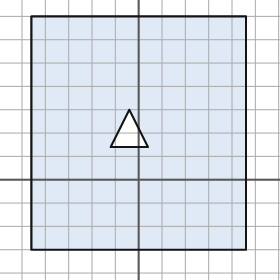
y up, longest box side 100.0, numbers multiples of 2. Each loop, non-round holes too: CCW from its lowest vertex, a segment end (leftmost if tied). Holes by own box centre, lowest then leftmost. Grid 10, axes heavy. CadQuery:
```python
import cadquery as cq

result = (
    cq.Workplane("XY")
    .moveTo(-46.0, -30.0)
    .lineTo(46.0, -30.0)
    .lineTo(46.0, 70.0)
    .lineTo(-46.0, 70.0)
    .close()
    .moveTo(-12.0, 14.0)
    .lineTo(4.0, 14.0)
    .lineTo(-4.0, 30.0)
    .close()
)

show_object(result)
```